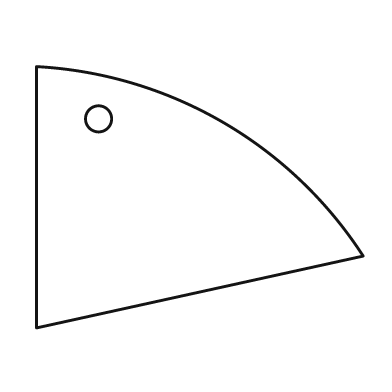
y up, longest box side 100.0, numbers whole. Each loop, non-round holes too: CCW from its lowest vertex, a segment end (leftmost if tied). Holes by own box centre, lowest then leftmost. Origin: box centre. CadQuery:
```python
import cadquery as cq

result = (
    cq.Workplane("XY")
    .moveTo(-50.0, -40.0)
    .lineTo(50.0, -18.0)
    .threePointArc((7.0, 23.0), (-50.0, 40.0))
    .close()
    .moveTo(-31.0, 24.0)
    .circle(4.0)
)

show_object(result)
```